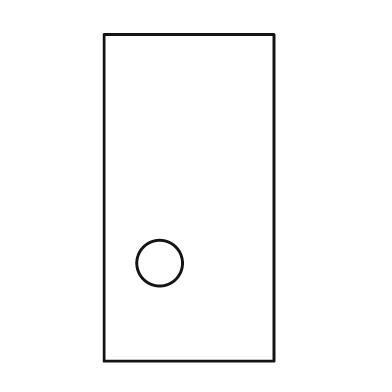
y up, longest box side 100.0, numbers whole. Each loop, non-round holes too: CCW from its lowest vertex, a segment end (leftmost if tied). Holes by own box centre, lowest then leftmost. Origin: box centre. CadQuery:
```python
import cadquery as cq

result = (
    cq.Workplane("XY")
    .moveTo(-26.0, -50.0)
    .lineTo(26.0, -50.0)
    .lineTo(26.0, 50.0)
    .lineTo(-26.0, 50.0)
    .close()
    .moveTo(-9.0, -20.0)
    .circle(7.0)
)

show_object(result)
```